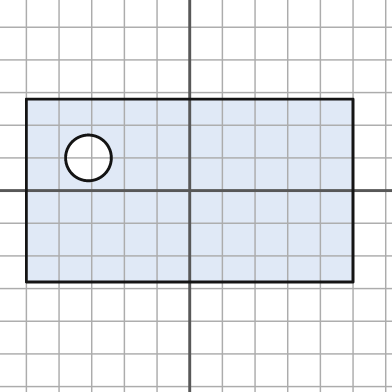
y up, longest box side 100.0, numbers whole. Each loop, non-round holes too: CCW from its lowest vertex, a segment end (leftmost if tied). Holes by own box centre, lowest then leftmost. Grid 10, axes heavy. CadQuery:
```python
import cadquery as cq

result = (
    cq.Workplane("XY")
    .moveTo(-50.0, -28.0)
    .lineTo(50.0, -28.0)
    .lineTo(50.0, 28.0)
    .lineTo(-50.0, 28.0)
    .close()
    .moveTo(-31.0, 10.0)
    .circle(7.0)
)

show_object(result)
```